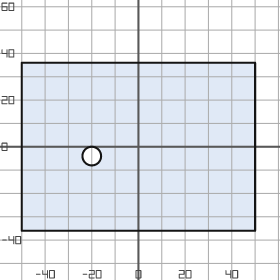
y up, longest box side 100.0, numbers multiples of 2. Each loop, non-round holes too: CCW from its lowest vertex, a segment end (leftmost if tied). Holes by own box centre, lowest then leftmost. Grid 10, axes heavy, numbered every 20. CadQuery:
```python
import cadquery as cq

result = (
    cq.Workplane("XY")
    .moveTo(-50.0, -36.0)
    .lineTo(50.0, -36.0)
    .lineTo(50.0, 36.0)
    .lineTo(-50.0, 36.0)
    .close()
    .moveTo(-20.0, -4.0)
    .circle(4.0)
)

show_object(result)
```